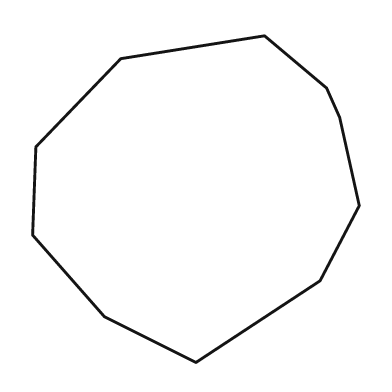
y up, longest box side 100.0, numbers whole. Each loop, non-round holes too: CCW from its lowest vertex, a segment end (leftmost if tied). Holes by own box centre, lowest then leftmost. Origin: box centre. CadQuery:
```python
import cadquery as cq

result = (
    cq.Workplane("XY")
    .moveTo(0.0, -50.0)
    .lineTo(38.0, -25.0)
    .lineTo(50.0, -2.0)
    .lineTo(44.0, 25.0)
    .lineTo(40.0, 34.0)
    .lineTo(21.0, 50.0)
    .lineTo(-23.0, 43.0)
    .lineTo(-49.0, 16.0)
    .lineTo(-50.0, -11.0)
    .lineTo(-28.0, -36.0)
    .close()
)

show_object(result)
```